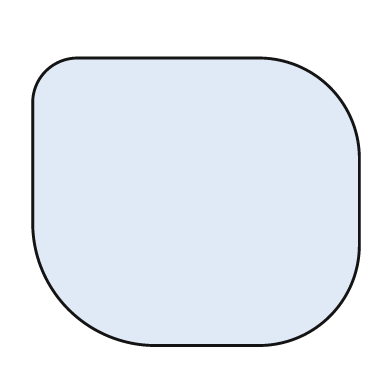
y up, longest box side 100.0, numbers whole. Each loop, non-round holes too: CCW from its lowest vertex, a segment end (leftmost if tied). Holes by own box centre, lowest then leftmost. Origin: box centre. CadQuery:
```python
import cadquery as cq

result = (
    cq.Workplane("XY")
    .moveTo(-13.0, -44.0)
    .lineTo(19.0, -44.0)
    .threePointArc((41.0, -35.0), (50.0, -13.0))
    .lineTo(50.0, 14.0)
    .threePointArc((41.0, 35.0), (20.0, 44.0))
    .lineTo(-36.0, 44.0)
    .threePointArc((-46.0, 40.0), (-50.0, 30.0))
    .lineTo(-50.0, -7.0)
    .threePointArc((-39.0, -33.0), (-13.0, -44.0))
    .close()
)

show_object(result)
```